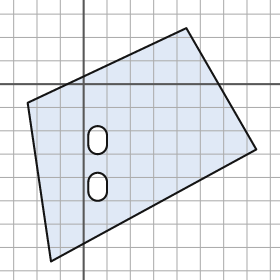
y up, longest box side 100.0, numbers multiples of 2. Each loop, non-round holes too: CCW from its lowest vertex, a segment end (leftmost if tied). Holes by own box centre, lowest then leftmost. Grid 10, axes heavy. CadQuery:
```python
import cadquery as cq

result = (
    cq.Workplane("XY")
    .moveTo(-14.0, -76.0)
    .lineTo(74.0, -28.0)
    .lineTo(44.0, 24.0)
    .lineTo(-24.0, -8.0)
    .close()
    .moveTo(2.0, -46.0)
    .threePointArc((6.0, -50.0), (10.0, -46.0))
    .lineTo(10.0, -42.0)
    .threePointArc((6.0, -38.0), (2.0, -42.0))
    .close()
    .moveTo(2.0, -26.0)
    .threePointArc((6.0, -30.0), (10.0, -26.0))
    .lineTo(10.0, -22.0)
    .threePointArc((6.0, -18.0), (2.0, -22.0))
    .close()
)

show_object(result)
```